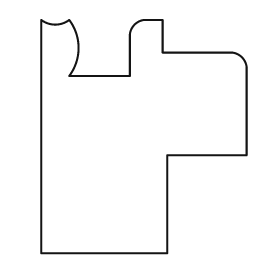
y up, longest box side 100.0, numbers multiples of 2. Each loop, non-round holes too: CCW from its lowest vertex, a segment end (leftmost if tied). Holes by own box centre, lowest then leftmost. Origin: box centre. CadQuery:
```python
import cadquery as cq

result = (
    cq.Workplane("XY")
    .moveTo(-44.0, -50.0)
    .lineTo(10.0, -50.0)
    .lineTo(10.0, -8.0)
    .lineTo(44.0, -8.0)
    .lineTo(44.0, 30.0)
    .threePointArc((42.0, 34.0), (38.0, 36.0))
    .lineTo(8.0, 36.0)
    .lineTo(8.0, 50.0)
    .lineTo(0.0, 50.0)
    .threePointArc((-4.0, 48.0), (-6.0, 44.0))
    .lineTo(-6.0, 26.0)
    .lineTo(-32.0, 26.0)
    .threePointArc((-28.0, 38.0), (-32.0, 50.0))
    .threePointArc((-38.0, 48.0), (-44.0, 50.0))
    .close()
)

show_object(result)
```